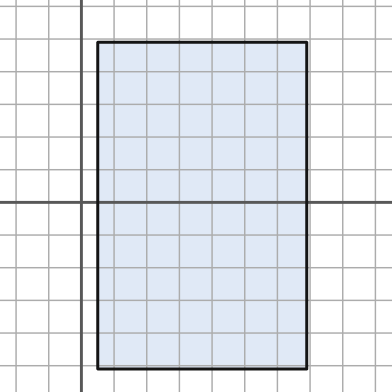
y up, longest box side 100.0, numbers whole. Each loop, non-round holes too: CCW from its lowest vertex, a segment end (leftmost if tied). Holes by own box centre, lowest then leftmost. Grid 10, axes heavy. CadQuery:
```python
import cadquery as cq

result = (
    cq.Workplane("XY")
    .moveTo(5.0, -51.0)
    .lineTo(69.0, -51.0)
    .lineTo(69.0, 49.0)
    .lineTo(5.0, 49.0)
    .close()
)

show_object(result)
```